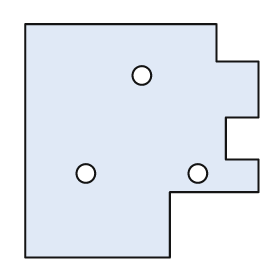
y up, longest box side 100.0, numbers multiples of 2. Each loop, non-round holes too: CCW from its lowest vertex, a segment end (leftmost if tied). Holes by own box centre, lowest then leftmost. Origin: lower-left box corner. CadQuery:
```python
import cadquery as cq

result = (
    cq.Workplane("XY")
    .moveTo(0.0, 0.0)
    .lineTo(62.0, 0.0)
    .lineTo(62.0, 28.0)
    .lineTo(100.0, 28.0)
    .lineTo(100.0, 42.0)
    .lineTo(86.0, 42.0)
    .lineTo(86.0, 60.0)
    .lineTo(100.0, 60.0)
    .lineTo(100.0, 84.0)
    .lineTo(82.0, 84.0)
    .lineTo(82.0, 100.0)
    .lineTo(0.0, 100.0)
    .close()
    .moveTo(26.0, 36.0)
    .circle(4.0)
    .moveTo(74.0, 36.0)
    .circle(4.0)
    .moveTo(50.0, 78.0)
    .circle(4.0)
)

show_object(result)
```